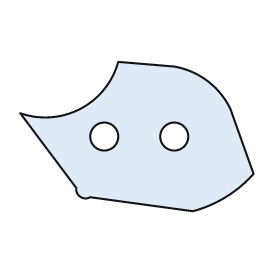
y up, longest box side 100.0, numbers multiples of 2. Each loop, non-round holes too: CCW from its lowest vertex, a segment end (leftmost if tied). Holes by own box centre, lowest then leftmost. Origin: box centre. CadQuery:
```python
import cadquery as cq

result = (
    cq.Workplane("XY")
    .moveTo(24.0, -32.0)
    .threePointArc((38.0, -26.0), (50.0, -16.0))
    .lineTo(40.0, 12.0)
    .threePointArc((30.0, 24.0), (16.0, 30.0))
    .lineTo(-8.0, 32.0)
    .threePointArc((-24.0, 12.0), (-50.0, 10.0))
    .lineTo(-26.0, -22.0)
    .threePointArc((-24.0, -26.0), (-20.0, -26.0))
    .close()
    .moveTo(-14.0, 0.0)
    .circle(6.0)
    .moveTo(16.0, 0.0)
    .circle(6.0)
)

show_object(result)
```